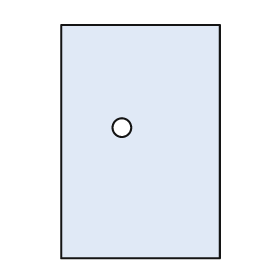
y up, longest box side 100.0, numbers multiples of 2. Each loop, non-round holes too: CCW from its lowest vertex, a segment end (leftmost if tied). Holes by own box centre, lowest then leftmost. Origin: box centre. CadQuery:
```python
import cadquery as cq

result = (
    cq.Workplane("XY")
    .moveTo(-34.0, -50.0)
    .lineTo(34.0, -50.0)
    .lineTo(34.0, 50.0)
    .lineTo(-34.0, 50.0)
    .close()
    .moveTo(-8.0, 6.0)
    .circle(4.0)
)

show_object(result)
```